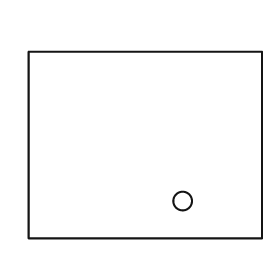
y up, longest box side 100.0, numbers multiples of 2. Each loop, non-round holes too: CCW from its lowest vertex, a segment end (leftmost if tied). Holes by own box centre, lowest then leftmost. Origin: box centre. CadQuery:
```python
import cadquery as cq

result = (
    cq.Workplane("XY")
    .moveTo(-50.0, -40.0)
    .lineTo(50.0, -40.0)
    .lineTo(50.0, 40.0)
    .lineTo(-50.0, 40.0)
    .close()
    .moveTo(16.0, -24.0)
    .circle(4.0)
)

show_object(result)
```